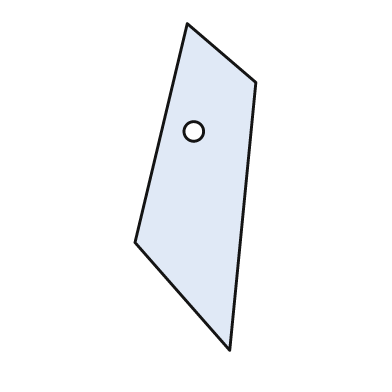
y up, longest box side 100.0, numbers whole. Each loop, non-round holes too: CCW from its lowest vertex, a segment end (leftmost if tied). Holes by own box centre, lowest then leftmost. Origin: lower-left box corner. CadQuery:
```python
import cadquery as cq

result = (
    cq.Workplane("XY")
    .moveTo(29.0, 0.0)
    .lineTo(37.0, 82.0)
    .lineTo(16.0, 100.0)
    .lineTo(0.0, 33.0)
    .close()
    .moveTo(18.0, 67.0)
    .circle(3.0)
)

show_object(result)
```